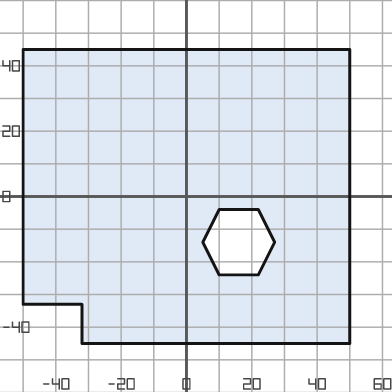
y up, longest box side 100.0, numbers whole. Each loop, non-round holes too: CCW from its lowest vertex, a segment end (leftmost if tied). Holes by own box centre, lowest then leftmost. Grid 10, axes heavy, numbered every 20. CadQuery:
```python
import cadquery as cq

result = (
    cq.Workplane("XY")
    .moveTo(-32.0, -45.0)
    .lineTo(50.0, -45.0)
    .lineTo(50.0, 45.0)
    .lineTo(-50.0, 45.0)
    .lineTo(-50.0, -33.0)
    .lineTo(-32.0, -33.0)
    .close()
    .moveTo(10.0, -24.0)
    .lineTo(22.0, -24.0)
    .lineTo(27.0, -14.0)
    .lineTo(22.0, -4.0)
    .lineTo(10.0, -4.0)
    .lineTo(5.0, -14.0)
    .close()
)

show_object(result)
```